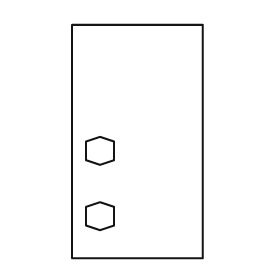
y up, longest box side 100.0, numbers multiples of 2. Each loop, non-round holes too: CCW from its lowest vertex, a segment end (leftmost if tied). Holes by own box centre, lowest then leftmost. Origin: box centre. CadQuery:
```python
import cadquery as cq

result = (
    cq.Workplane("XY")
    .moveTo(-28.0, -50.0)
    .lineTo(28.0, -50.0)
    .lineTo(28.0, 50.0)
    .lineTo(-28.0, 50.0)
    .close()
    .moveTo(-16.0, -38.0)
    .lineTo(-10.0, -36.0)
    .lineTo(-10.0, -28.0)
    .lineTo(-16.0, -26.0)
    .lineTo(-22.0, -28.0)
    .lineTo(-22.0, -36.0)
    .close()
    .moveTo(-16.0, -10.0)
    .lineTo(-10.0, -8.0)
    .lineTo(-10.0, 0.0)
    .lineTo(-16.0, 2.0)
    .lineTo(-22.0, 0.0)
    .lineTo(-22.0, -8.0)
    .close()
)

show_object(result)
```